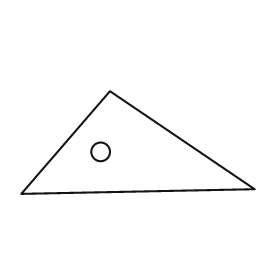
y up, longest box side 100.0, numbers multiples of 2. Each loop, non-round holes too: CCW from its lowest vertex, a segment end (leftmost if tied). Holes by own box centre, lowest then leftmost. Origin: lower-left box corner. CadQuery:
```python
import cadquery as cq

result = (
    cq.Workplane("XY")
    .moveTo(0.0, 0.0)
    .lineTo(100.0, 2.0)
    .lineTo(38.0, 44.0)
    .close()
    .moveTo(34.0, 18.0)
    .circle(4.0)
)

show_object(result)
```